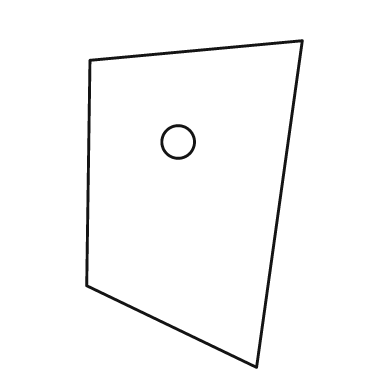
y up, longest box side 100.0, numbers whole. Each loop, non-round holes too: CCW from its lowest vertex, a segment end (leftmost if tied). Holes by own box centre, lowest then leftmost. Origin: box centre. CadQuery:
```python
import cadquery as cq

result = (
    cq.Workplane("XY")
    .moveTo(19.0, -50.0)
    .lineTo(33.0, 50.0)
    .lineTo(-32.0, 44.0)
    .lineTo(-33.0, -25.0)
    .close()
    .moveTo(-5.0, 19.0)
    .circle(5.0)
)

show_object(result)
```